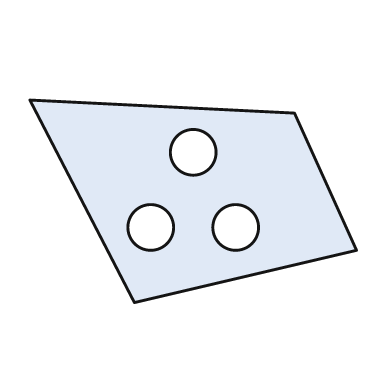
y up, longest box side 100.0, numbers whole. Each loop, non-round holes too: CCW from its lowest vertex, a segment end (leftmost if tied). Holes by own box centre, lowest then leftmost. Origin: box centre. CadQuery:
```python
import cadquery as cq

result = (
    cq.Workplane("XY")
    .moveTo(-18.0, -31.0)
    .lineTo(50.0, -15.0)
    .lineTo(31.0, 27.0)
    .lineTo(-50.0, 31.0)
    .close()
    .moveTo(-13.0, -8.0)
    .circle(7.0)
    .moveTo(13.0, -8.0)
    .circle(7.0)
    .moveTo(0.0, 15.0)
    .circle(7.0)
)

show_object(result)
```